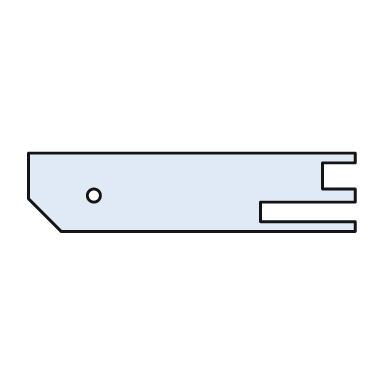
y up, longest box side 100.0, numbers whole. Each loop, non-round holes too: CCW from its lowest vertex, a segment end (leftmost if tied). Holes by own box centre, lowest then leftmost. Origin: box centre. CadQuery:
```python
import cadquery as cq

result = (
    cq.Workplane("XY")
    .moveTo(-40.0, -12.0)
    .lineTo(50.0, -12.0)
    .lineTo(50.0, -9.0)
    .lineTo(21.0, -9.0)
    .lineTo(21.0, -3.0)
    .lineTo(50.0, -3.0)
    .lineTo(50.0, 1.0)
    .lineTo(40.0, 1.0)
    .lineTo(40.0, 9.0)
    .lineTo(50.0, 9.0)
    .lineTo(50.0, 12.0)
    .lineTo(-50.0, 12.0)
    .lineTo(-50.0, -2.0)
    .close()
    .moveTo(-30.0, -1.0)
    .circle(2.0)
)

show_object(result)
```